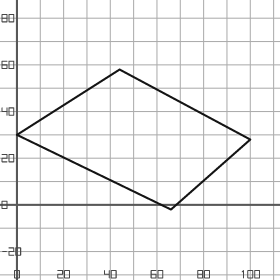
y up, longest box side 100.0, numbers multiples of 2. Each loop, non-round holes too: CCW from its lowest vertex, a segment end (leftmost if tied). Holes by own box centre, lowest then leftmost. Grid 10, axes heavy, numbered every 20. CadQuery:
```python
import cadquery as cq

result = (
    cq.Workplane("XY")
    .moveTo(66.0, -2.0)
    .lineTo(100.0, 28.0)
    .lineTo(44.0, 58.0)
    .lineTo(0.0, 30.0)
    .close()
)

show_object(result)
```